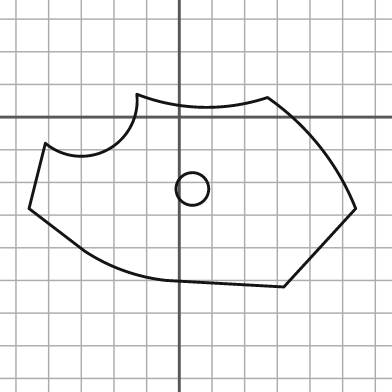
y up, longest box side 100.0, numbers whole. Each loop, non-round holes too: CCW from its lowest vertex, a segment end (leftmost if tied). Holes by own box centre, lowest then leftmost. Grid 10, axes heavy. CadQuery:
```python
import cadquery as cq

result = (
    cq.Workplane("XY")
    .moveTo(32.0, -52.0)
    .lineTo(54.0, -28.0)
    .threePointArc((43.0, -9.0), (27.0, 6.0))
    .threePointArc((7.0, 3.0), (-13.0, 7.0))
    .threePointArc((-22.0, -10.0), (-41.0, -8.0))
    .lineTo(-46.0, -28.0)
    .lineTo(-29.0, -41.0)
    .threePointArc((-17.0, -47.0), (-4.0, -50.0))
    .close()
    .moveTo(4.0, -22.0)
    .circle(5.0)
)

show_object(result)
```